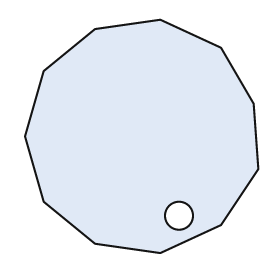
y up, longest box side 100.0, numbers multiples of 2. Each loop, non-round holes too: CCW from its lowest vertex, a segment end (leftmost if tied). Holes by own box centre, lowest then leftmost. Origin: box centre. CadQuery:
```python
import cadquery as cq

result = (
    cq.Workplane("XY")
    .moveTo(8.0, -50.0)
    .lineTo(34.0, -38.0)
    .lineTo(50.0, -14.0)
    .lineTo(48.0, 14.0)
    .lineTo(34.0, 38.0)
    .lineTo(8.0, 50.0)
    .lineTo(-20.0, 46.0)
    .lineTo(-42.0, 28.0)
    .lineTo(-50.0, 0.0)
    .lineTo(-42.0, -28.0)
    .lineTo(-20.0, -46.0)
    .close()
    .moveTo(16.0, -34.0)
    .circle(6.0)
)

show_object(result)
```